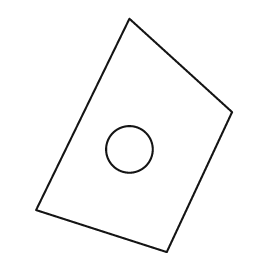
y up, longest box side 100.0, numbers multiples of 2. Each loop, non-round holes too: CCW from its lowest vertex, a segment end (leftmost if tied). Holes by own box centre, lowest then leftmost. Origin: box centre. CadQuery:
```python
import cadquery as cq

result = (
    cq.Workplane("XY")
    .moveTo(14.0, -50.0)
    .lineTo(42.0, 10.0)
    .lineTo(-2.0, 50.0)
    .lineTo(-42.0, -32.0)
    .close()
    .moveTo(-2.0, -6.0)
    .circle(10.0)
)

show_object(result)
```